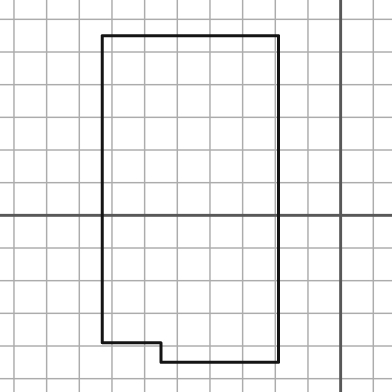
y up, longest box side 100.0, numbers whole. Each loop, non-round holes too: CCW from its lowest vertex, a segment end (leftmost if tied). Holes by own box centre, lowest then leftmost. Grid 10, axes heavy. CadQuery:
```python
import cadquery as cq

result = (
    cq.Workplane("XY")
    .moveTo(-55.0, -45.0)
    .lineTo(-19.0, -45.0)
    .lineTo(-19.0, 55.0)
    .lineTo(-73.0, 55.0)
    .lineTo(-73.0, -39.0)
    .lineTo(-55.0, -39.0)
    .close()
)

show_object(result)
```